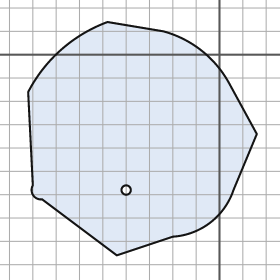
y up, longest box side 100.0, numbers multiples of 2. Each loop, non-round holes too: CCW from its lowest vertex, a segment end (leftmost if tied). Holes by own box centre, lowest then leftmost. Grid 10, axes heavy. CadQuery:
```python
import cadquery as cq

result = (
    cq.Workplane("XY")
    .moveTo(-44.0, -86.0)
    .lineTo(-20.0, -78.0)
    .threePointArc((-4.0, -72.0), (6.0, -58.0))
    .lineTo(16.0, -34.0)
    .lineTo(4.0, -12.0)
    .threePointArc((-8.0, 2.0), (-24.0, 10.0))
    .lineTo(-48.0, 14.0)
    .threePointArc((-68.0, 2.0), (-82.0, -16.0))
    .lineTo(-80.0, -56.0)
    .threePointArc((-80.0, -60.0), (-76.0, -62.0))
    .close()
    .moveTo(-40.0, -58.0)
    .circle(2.0)
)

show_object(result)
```